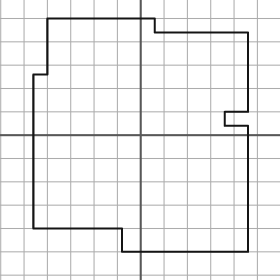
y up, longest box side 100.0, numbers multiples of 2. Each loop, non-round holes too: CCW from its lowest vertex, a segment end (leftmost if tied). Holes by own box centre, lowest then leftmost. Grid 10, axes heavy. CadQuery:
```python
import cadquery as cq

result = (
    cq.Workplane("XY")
    .moveTo(-8.0, -50.0)
    .lineTo(46.0, -50.0)
    .lineTo(46.0, 4.0)
    .lineTo(36.0, 4.0)
    .lineTo(36.0, 10.0)
    .lineTo(46.0, 10.0)
    .lineTo(46.0, 44.0)
    .lineTo(6.0, 44.0)
    .lineTo(6.0, 50.0)
    .lineTo(-40.0, 50.0)
    .lineTo(-40.0, 26.0)
    .lineTo(-46.0, 26.0)
    .lineTo(-46.0, -40.0)
    .lineTo(-8.0, -40.0)
    .close()
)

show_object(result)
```